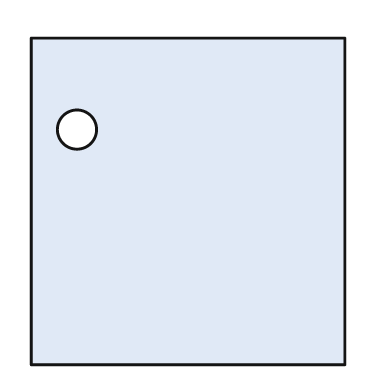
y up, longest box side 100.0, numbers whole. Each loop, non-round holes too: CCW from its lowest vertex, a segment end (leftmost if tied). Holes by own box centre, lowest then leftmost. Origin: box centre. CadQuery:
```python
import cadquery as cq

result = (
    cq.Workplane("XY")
    .moveTo(-48.0, -50.0)
    .lineTo(48.0, -50.0)
    .lineTo(48.0, 50.0)
    .lineTo(-48.0, 50.0)
    .close()
    .moveTo(-34.0, 22.0)
    .circle(6.0)
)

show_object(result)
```